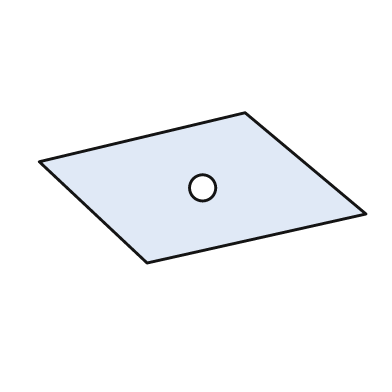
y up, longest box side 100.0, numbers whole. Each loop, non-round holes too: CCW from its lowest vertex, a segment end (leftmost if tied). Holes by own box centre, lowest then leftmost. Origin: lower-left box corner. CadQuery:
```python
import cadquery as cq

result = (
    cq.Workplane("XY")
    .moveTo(33.0, 0.0)
    .lineTo(100.0, 15.0)
    .lineTo(63.0, 46.0)
    .lineTo(0.0, 31.0)
    .close()
    .moveTo(50.0, 23.0)
    .circle(4.0)
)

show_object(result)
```